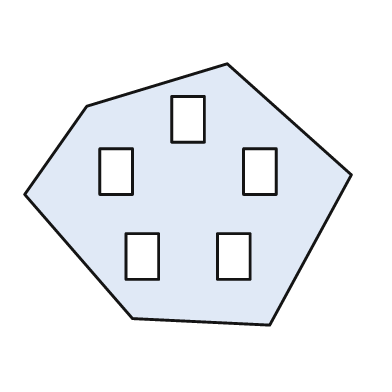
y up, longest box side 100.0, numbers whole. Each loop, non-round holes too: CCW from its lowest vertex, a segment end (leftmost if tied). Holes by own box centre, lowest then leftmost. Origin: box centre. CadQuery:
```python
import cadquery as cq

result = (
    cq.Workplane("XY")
    .moveTo(25.0, -40.0)
    .lineTo(50.0, 6.0)
    .lineTo(12.0, 40.0)
    .lineTo(-31.0, 27.0)
    .lineTo(-50.0, 0.0)
    .lineTo(-17.0, -38.0)
    .close()
    .moveTo(-19.0, -26.0)
    .lineTo(-9.0, -26.0)
    .lineTo(-9.0, -12.0)
    .lineTo(-19.0, -12.0)
    .close()
    .moveTo(9.0, -26.0)
    .lineTo(19.0, -26.0)
    .lineTo(19.0, -12.0)
    .lineTo(9.0, -12.0)
    .close()
    .moveTo(-27.0, 0.0)
    .lineTo(-17.0, 0.0)
    .lineTo(-17.0, 14.0)
    .lineTo(-27.0, 14.0)
    .close()
    .moveTo(17.0, 0.0)
    .lineTo(27.0, 0.0)
    .lineTo(27.0, 14.0)
    .lineTo(17.0, 14.0)
    .close()
    .moveTo(-5.0, 16.0)
    .lineTo(5.0, 16.0)
    .lineTo(5.0, 30.0)
    .lineTo(-5.0, 30.0)
    .close()
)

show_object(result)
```